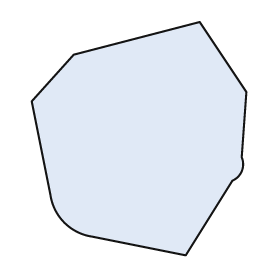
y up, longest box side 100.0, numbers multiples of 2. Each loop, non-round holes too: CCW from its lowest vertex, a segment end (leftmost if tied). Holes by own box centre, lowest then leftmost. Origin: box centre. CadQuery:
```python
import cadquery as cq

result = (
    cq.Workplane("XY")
    .moveTo(20.0, -50.0)
    .lineTo(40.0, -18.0)
    .threePointArc((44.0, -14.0), (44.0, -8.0))
    .lineTo(46.0, 20.0)
    .lineTo(26.0, 50.0)
    .lineTo(-28.0, 36.0)
    .lineTo(-46.0, 16.0)
    .lineTo(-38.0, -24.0)
    .threePointArc((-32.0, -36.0), (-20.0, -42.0))
    .close()
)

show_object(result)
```